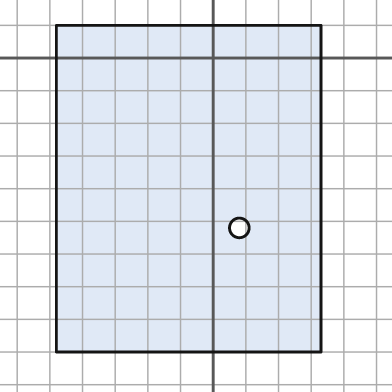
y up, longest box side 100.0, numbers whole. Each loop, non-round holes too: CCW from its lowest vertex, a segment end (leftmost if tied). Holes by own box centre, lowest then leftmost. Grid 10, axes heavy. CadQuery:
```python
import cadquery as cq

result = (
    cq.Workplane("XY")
    .moveTo(-48.0, -90.0)
    .lineTo(33.0, -90.0)
    .lineTo(33.0, 10.0)
    .lineTo(-48.0, 10.0)
    .close()
    .moveTo(8.0, -52.0)
    .circle(3.0)
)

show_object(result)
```